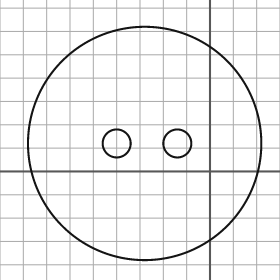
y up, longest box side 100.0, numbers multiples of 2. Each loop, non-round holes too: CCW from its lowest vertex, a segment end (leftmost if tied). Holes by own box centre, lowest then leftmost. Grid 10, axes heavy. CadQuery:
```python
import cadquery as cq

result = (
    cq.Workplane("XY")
    .moveTo(-28.0, 12.0)
    .circle(50.0)
    .moveTo(-40.0, 12.0)
    .circle(6.0)
    .moveTo(-14.0, 12.0)
    .circle(6.0)
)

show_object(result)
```